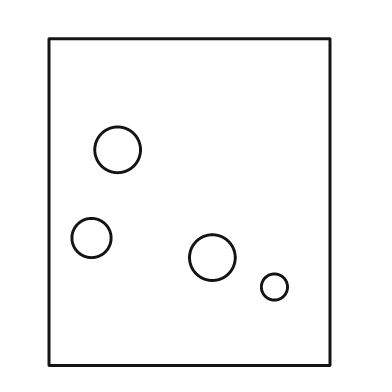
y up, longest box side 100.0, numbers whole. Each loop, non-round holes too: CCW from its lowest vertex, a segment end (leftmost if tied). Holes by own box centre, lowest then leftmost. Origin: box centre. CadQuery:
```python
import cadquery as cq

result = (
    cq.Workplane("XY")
    .moveTo(-43.0, -50.0)
    .lineTo(43.0, -50.0)
    .lineTo(43.0, 50.0)
    .lineTo(-43.0, 50.0)
    .close()
    .moveTo(26.0, -26.0)
    .circle(4.0)
    .moveTo(7.0, -17.0)
    .circle(7.0)
    .moveTo(-30.0, -11.0)
    .circle(6.0)
    .moveTo(-22.0, 16.0)
    .circle(7.0)
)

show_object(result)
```